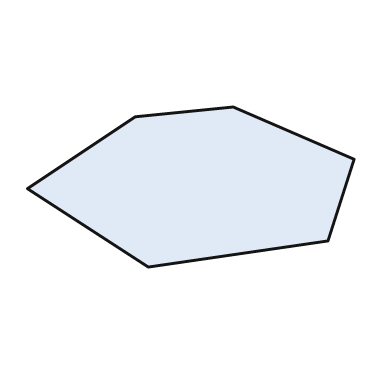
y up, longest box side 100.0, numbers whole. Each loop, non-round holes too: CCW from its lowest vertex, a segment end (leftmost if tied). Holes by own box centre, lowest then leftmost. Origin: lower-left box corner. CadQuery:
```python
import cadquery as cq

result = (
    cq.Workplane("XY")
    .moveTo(37.0, 0.0)
    .lineTo(92.0, 8.0)
    .lineTo(100.0, 33.0)
    .lineTo(63.0, 49.0)
    .lineTo(33.0, 46.0)
    .lineTo(0.0, 24.0)
    .close()
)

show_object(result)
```